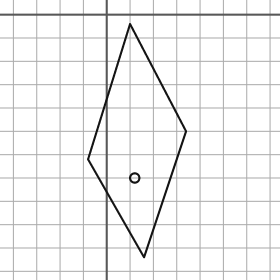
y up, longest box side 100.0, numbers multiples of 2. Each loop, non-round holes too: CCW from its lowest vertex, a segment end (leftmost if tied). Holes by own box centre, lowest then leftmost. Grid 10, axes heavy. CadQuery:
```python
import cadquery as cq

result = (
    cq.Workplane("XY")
    .moveTo(16.0, -104.0)
    .lineTo(34.0, -50.0)
    .lineTo(10.0, -4.0)
    .lineTo(-8.0, -62.0)
    .close()
    .moveTo(12.0, -70.0)
    .circle(2.0)
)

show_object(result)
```